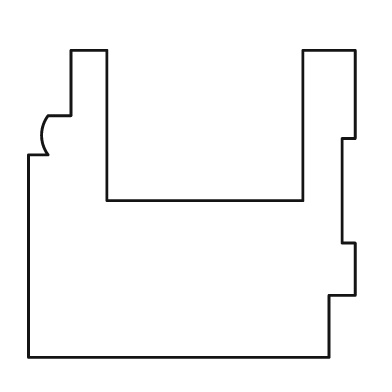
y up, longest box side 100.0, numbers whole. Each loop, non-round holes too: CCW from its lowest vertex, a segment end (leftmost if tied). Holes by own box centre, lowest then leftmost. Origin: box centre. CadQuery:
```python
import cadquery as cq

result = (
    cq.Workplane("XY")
    .moveTo(-50.0, -47.0)
    .lineTo(42.0, -47.0)
    .lineTo(42.0, -28.0)
    .lineTo(50.0, -28.0)
    .lineTo(50.0, -12.0)
    .lineTo(46.0, -12.0)
    .lineTo(46.0, 20.0)
    .lineTo(50.0, 20.0)
    .lineTo(50.0, 47.0)
    .lineTo(34.0, 47.0)
    .lineTo(34.0, 1.0)
    .lineTo(-26.0, 1.0)
    .lineTo(-26.0, 47.0)
    .lineTo(-37.0, 47.0)
    .lineTo(-37.0, 27.0)
    .lineTo(-44.0, 27.0)
    .threePointArc((-46.0, 21.0), (-44.0, 15.0))
    .lineTo(-50.0, 15.0)
    .close()
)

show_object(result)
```